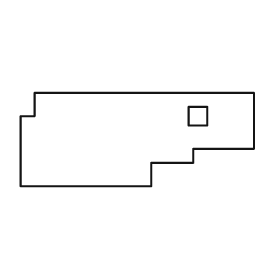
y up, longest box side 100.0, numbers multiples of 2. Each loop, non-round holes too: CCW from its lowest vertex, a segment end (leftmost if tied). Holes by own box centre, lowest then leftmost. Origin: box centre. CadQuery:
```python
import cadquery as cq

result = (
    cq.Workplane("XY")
    .moveTo(-50.0, -20.0)
    .lineTo(6.0, -20.0)
    .lineTo(6.0, -10.0)
    .lineTo(24.0, -10.0)
    .lineTo(24.0, -4.0)
    .lineTo(50.0, -4.0)
    .lineTo(50.0, 20.0)
    .lineTo(-44.0, 20.0)
    .lineTo(-44.0, 10.0)
    .lineTo(-50.0, 10.0)
    .close()
    .moveTo(22.0, 6.0)
    .lineTo(30.0, 6.0)
    .lineTo(30.0, 14.0)
    .lineTo(22.0, 14.0)
    .close()
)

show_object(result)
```